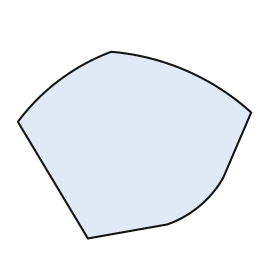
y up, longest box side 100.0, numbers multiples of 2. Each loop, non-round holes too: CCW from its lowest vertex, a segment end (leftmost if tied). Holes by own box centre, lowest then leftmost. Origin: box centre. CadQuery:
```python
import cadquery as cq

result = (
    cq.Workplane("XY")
    .moveTo(-20.0, -40.0)
    .lineTo(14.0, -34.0)
    .threePointArc((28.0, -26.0), (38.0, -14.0))
    .lineTo(50.0, 14.0)
    .threePointArc((22.0, 32.0), (-10.0, 40.0))
    .threePointArc((-32.0, 28.0), (-50.0, 10.0))
    .close()
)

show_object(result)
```